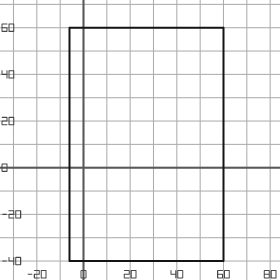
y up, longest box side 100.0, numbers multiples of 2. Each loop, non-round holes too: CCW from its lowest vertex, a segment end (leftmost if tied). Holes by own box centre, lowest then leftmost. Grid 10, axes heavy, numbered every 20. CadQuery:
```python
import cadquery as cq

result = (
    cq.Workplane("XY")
    .moveTo(-6.0, -40.0)
    .lineTo(60.0, -40.0)
    .lineTo(60.0, 60.0)
    .lineTo(-6.0, 60.0)
    .close()
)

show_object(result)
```